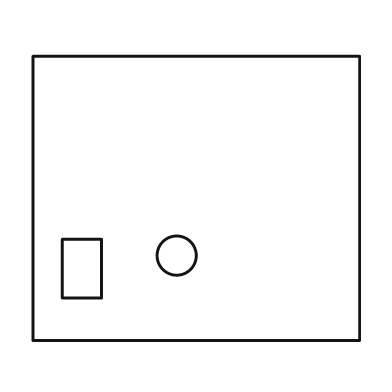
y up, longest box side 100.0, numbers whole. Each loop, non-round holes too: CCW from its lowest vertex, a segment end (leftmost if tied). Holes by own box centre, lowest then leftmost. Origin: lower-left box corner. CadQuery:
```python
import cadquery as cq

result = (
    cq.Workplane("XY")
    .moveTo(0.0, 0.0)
    .lineTo(100.0, 0.0)
    .lineTo(100.0, 87.0)
    .lineTo(0.0, 87.0)
    .close()
    .moveTo(9.0, 13.0)
    .lineTo(21.0, 13.0)
    .lineTo(21.0, 31.0)
    .lineTo(9.0, 31.0)
    .close()
    .moveTo(44.0, 26.0)
    .circle(6.0)
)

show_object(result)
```